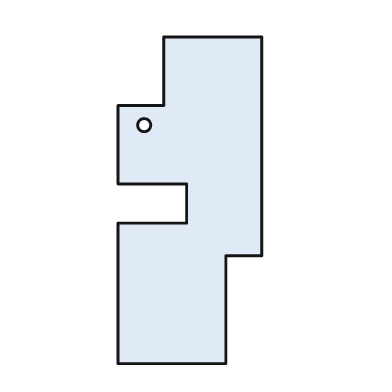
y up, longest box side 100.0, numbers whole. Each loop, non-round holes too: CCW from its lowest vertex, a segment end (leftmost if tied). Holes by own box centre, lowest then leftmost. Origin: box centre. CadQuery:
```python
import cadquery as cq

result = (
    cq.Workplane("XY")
    .moveTo(-22.0, -50.0)
    .lineTo(11.0, -50.0)
    .lineTo(11.0, -17.0)
    .lineTo(22.0, -17.0)
    .lineTo(22.0, 50.0)
    .lineTo(-8.0, 50.0)
    .lineTo(-8.0, 29.0)
    .lineTo(-22.0, 29.0)
    .lineTo(-22.0, 5.0)
    .lineTo(-1.0, 5.0)
    .lineTo(-1.0, -7.0)
    .lineTo(-22.0, -7.0)
    .close()
    .moveTo(-14.0, 23.0)
    .circle(2.0)
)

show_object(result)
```